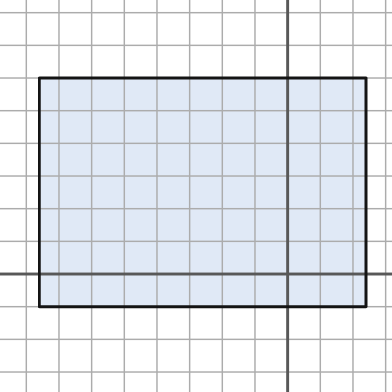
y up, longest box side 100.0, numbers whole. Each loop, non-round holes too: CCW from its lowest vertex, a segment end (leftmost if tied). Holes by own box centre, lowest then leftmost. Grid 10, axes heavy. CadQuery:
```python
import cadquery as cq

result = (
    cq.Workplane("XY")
    .moveTo(-76.0, -10.0)
    .lineTo(24.0, -10.0)
    .lineTo(24.0, 60.0)
    .lineTo(-76.0, 60.0)
    .close()
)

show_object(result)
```